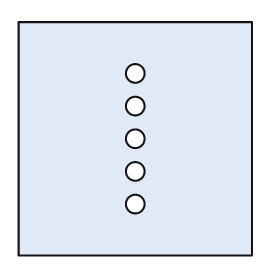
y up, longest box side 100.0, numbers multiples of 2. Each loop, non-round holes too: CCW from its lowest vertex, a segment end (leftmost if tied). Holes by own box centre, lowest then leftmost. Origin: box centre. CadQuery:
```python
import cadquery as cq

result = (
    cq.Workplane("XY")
    .moveTo(-50.0, -50.0)
    .lineTo(50.0, -50.0)
    .lineTo(50.0, 50.0)
    .lineTo(-50.0, 50.0)
    .close()
    .moveTo(0.0, -28.0)
    .circle(4.0)
    .moveTo(0.0, -14.0)
    .circle(4.0)
    .moveTo(0.0, 0.0)
    .circle(4.0)
    .moveTo(0.0, 14.0)
    .circle(4.0)
    .moveTo(0.0, 28.0)
    .circle(4.0)
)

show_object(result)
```